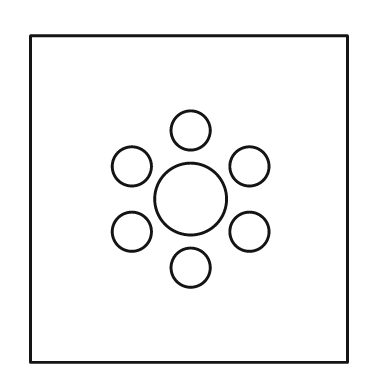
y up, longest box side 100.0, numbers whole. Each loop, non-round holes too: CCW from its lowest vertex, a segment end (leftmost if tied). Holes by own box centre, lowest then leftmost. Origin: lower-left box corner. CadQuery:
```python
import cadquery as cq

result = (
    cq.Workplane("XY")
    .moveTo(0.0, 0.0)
    .lineTo(97.0, 0.0)
    .lineTo(97.0, 100.0)
    .lineTo(0.0, 100.0)
    .close()
    .moveTo(49.0, 29.0)
    .circle(6.0)
    .moveTo(31.0, 40.0)
    .circle(6.0)
    .moveTo(67.0, 40.0)
    .circle(6.0)
    .moveTo(49.0, 50.0)
    .circle(11.0)
    .moveTo(31.0, 60.0)
    .circle(6.0)
    .moveTo(67.0, 60.0)
    .circle(6.0)
    .moveTo(49.0, 71.0)
    .circle(6.0)
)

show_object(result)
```